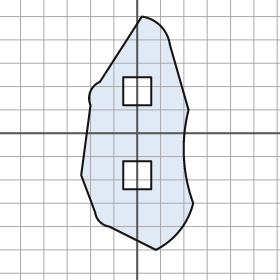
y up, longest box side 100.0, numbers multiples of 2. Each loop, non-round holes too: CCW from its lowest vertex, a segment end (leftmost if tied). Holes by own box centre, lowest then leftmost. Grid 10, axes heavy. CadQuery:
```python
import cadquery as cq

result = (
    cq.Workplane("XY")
    .moveTo(8.0, -50.0)
    .threePointArc((18.0, -42.0), (24.0, -30.0))
    .threePointArc((20.0, -10.0), (22.0, 10.0))
    .lineTo(14.0, 38.0)
    .threePointArc((10.0, 46.0), (2.0, 50.0))
    .lineTo(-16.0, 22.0)
    .threePointArc((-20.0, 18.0), (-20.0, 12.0))
    .lineTo(-24.0, -18.0)
    .lineTo(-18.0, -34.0)
    .threePointArc((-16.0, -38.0), (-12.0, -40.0))
    .close()
    .moveTo(-6.0, -24.0)
    .lineTo(6.0, -24.0)
    .lineTo(6.0, -12.0)
    .lineTo(-6.0, -12.0)
    .close()
    .moveTo(-6.0, 12.0)
    .lineTo(6.0, 12.0)
    .lineTo(6.0, 24.0)
    .lineTo(-6.0, 24.0)
    .close()
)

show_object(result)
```